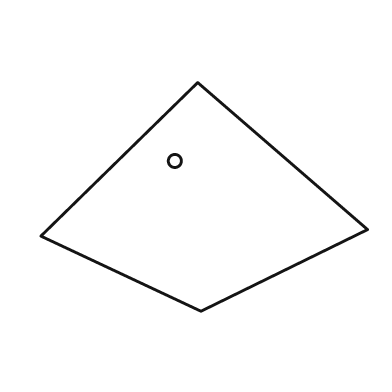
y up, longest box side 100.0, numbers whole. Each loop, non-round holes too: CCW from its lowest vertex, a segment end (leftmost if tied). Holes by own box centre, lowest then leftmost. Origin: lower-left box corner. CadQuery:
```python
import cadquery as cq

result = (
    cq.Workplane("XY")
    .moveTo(49.0, 0.0)
    .lineTo(100.0, 25.0)
    .lineTo(48.0, 70.0)
    .lineTo(0.0, 23.0)
    .close()
    .moveTo(41.0, 46.0)
    .circle(2.0)
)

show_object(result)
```